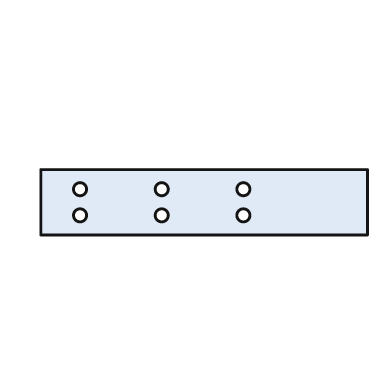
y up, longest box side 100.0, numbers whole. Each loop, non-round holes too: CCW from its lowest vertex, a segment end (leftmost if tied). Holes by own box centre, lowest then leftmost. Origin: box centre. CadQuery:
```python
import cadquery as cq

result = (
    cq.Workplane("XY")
    .moveTo(-50.0, -10.0)
    .lineTo(50.0, -10.0)
    .lineTo(50.0, 10.0)
    .lineTo(-50.0, 10.0)
    .close()
    .moveTo(-38.0, -4.0)
    .circle(2.0)
    .moveTo(-13.0, -4.0)
    .circle(2.0)
    .moveTo(12.0, -4.0)
    .circle(2.0)
    .moveTo(-38.0, 4.0)
    .circle(2.0)
    .moveTo(-13.0, 4.0)
    .circle(2.0)
    .moveTo(12.0, 4.0)
    .circle(2.0)
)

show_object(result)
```